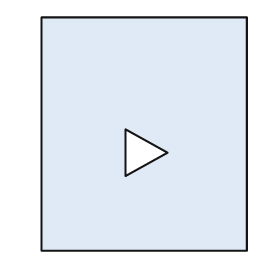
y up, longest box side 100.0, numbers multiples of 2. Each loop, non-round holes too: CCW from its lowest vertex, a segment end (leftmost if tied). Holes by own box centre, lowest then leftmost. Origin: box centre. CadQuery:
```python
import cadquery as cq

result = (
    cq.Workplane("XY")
    .moveTo(-44.0, -50.0)
    .lineTo(44.0, -50.0)
    .lineTo(44.0, 50.0)
    .lineTo(-44.0, 50.0)
    .close()
    .moveTo(-8.0, -18.0)
    .lineTo(10.0, -8.0)
    .lineTo(-8.0, 2.0)
    .close()
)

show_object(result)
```